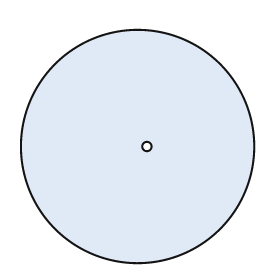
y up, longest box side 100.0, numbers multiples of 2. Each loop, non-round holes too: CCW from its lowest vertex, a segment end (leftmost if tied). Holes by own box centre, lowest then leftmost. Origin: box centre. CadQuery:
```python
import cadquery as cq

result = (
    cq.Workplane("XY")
    .moveTo(0.0, 0.0)
    .circle(50.0)
    .moveTo(4.0, 0.0)
    .circle(2.0)
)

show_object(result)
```